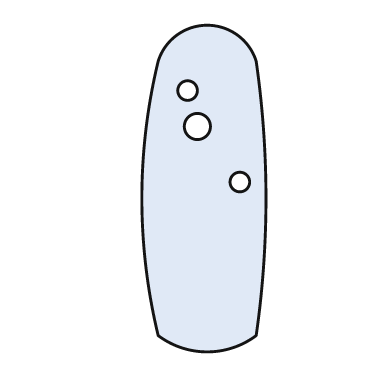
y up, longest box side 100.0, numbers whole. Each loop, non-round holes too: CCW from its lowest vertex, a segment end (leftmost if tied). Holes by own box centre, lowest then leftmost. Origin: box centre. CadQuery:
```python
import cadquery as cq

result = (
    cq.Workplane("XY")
    .moveTo(-14.0, -45.0)
    .threePointArc((1.0, -50.0), (16.0, -45.0))
    .threePointArc((19.0, -3.0), (16.0, 39.0))
    .threePointArc((1.0, 50.0), (-14.0, 39.0))
    .threePointArc((-19.0, -3.0), (-14.0, -45.0))
    .close()
    .moveTo(11.0, 2.0)
    .circle(3.0)
    .moveTo(-2.0, 19.0)
    .circle(4.0)
    .moveTo(-5.0, 30.0)
    .circle(3.0)
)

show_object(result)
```